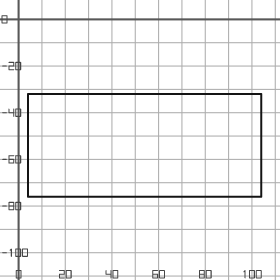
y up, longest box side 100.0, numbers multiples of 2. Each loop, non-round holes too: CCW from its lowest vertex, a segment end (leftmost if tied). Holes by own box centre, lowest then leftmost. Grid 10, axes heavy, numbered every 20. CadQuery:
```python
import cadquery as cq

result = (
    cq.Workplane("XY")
    .moveTo(4.0, -76.0)
    .lineTo(104.0, -76.0)
    .lineTo(104.0, -32.0)
    .lineTo(4.0, -32.0)
    .close()
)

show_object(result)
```